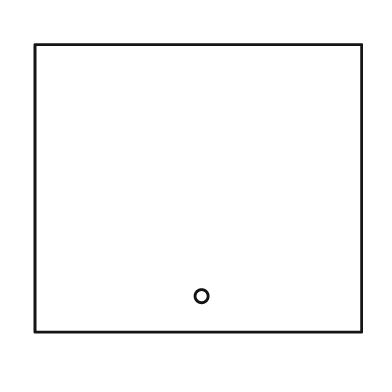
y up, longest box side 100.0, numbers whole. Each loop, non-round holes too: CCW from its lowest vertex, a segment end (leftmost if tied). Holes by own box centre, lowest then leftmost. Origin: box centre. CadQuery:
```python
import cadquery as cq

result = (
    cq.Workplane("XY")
    .moveTo(-50.0, -44.0)
    .lineTo(50.0, -44.0)
    .lineTo(50.0, 44.0)
    .lineTo(-50.0, 44.0)
    .close()
    .moveTo(1.0, -33.0)
    .circle(2.0)
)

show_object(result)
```